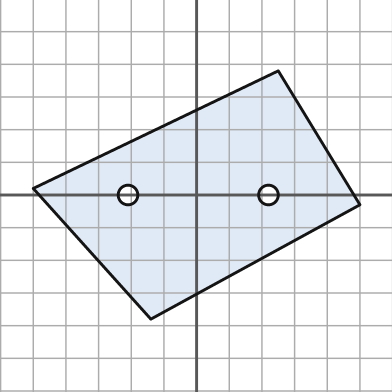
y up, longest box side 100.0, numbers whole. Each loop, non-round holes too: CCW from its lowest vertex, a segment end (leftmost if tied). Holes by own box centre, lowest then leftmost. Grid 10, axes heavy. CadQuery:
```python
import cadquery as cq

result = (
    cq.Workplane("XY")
    .moveTo(-14.0, -38.0)
    .lineTo(50.0, -3.0)
    .lineTo(25.0, 38.0)
    .lineTo(-50.0, 2.0)
    .close()
    .moveTo(-21.0, 0.0)
    .circle(3.0)
    .moveTo(22.0, 0.0)
    .circle(3.0)
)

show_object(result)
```